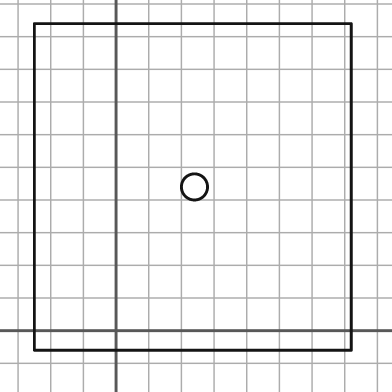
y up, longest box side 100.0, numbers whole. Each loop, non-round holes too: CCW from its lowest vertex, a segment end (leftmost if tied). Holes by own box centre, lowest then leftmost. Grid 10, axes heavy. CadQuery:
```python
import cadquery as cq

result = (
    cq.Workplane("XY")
    .moveTo(-25.0, -6.0)
    .lineTo(72.0, -6.0)
    .lineTo(72.0, 94.0)
    .lineTo(-25.0, 94.0)
    .close()
    .moveTo(24.0, 44.0)
    .circle(4.0)
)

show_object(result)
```